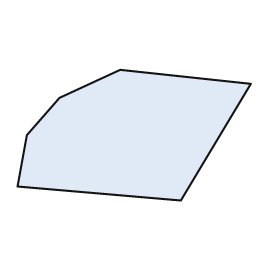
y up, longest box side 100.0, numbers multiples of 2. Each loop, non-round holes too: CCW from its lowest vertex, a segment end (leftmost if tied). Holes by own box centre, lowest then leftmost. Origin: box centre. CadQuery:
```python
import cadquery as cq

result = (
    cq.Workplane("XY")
    .moveTo(20.0, -28.0)
    .lineTo(50.0, 22.0)
    .lineTo(-6.0, 28.0)
    .lineTo(-32.0, 16.0)
    .lineTo(-46.0, 0.0)
    .lineTo(-50.0, -22.0)
    .close()
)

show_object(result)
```